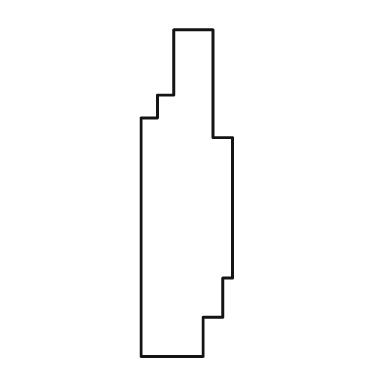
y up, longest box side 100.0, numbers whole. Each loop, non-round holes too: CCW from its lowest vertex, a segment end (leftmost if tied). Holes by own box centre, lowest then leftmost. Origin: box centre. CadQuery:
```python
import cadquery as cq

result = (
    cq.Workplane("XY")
    .moveTo(-14.0, -50.0)
    .lineTo(5.0, -50.0)
    .lineTo(5.0, -38.0)
    .lineTo(11.0, -38.0)
    .lineTo(11.0, -26.0)
    .lineTo(14.0, -26.0)
    .lineTo(14.0, 17.0)
    .lineTo(8.0, 17.0)
    .lineTo(8.0, 50.0)
    .lineTo(-4.0, 50.0)
    .lineTo(-4.0, 30.0)
    .lineTo(-9.0, 30.0)
    .lineTo(-9.0, 23.0)
    .lineTo(-14.0, 23.0)
    .close()
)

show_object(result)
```